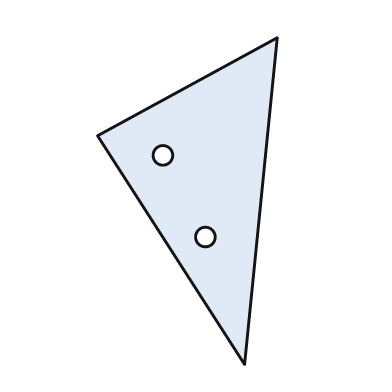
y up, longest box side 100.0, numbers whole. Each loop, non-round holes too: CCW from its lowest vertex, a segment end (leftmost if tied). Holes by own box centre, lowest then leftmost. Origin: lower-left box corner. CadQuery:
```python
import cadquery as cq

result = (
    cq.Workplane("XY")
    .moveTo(45.0, 0.0)
    .lineTo(55.0, 100.0)
    .lineTo(0.0, 70.0)
    .close()
    .moveTo(33.0, 39.0)
    .circle(3.0)
    .moveTo(20.0, 64.0)
    .circle(3.0)
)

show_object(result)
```